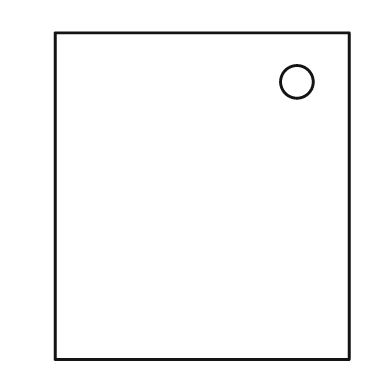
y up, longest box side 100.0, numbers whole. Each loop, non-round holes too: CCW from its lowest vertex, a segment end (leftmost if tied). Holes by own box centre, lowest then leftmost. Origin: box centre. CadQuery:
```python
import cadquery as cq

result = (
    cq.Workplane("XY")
    .moveTo(-45.0, -50.0)
    .lineTo(45.0, -50.0)
    .lineTo(45.0, 50.0)
    .lineTo(-45.0, 50.0)
    .close()
    .moveTo(29.0, 35.0)
    .circle(5.0)
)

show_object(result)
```